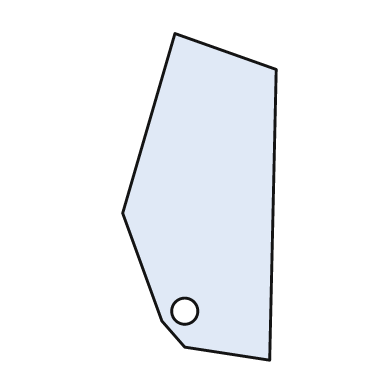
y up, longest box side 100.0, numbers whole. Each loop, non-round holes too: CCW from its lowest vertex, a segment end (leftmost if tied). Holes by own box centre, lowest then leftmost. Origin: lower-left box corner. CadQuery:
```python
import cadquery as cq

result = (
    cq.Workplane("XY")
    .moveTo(45.0, 0.0)
    .lineTo(47.0, 89.0)
    .lineTo(16.0, 100.0)
    .lineTo(0.0, 45.0)
    .lineTo(12.0, 12.0)
    .lineTo(19.0, 4.0)
    .close()
    .moveTo(19.0, 15.0)
    .circle(4.0)
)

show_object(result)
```